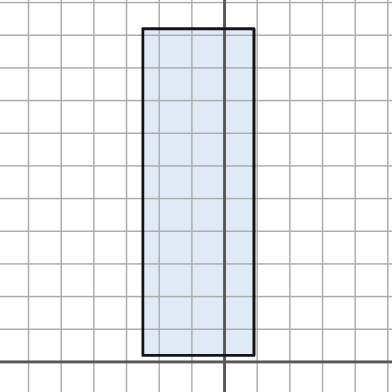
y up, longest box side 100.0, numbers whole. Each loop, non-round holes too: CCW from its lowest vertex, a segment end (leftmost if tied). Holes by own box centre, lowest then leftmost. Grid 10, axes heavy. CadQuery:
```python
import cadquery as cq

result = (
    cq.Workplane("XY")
    .moveTo(-25.0, 2.0)
    .lineTo(9.0, 2.0)
    .lineTo(9.0, 102.0)
    .lineTo(-25.0, 102.0)
    .close()
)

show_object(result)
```